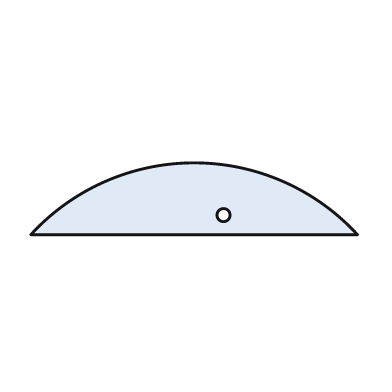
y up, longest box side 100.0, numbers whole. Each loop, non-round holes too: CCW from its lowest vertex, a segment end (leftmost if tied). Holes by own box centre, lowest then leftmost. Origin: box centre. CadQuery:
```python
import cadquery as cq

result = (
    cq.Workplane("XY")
    .moveTo(-50.0, -11.0)
    .lineTo(50.0, -11.0)
    .threePointArc((0.0, 11.0), (-50.0, -11.0))
    .close()
    .moveTo(9.0, -5.0)
    .circle(2.0)
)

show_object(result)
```